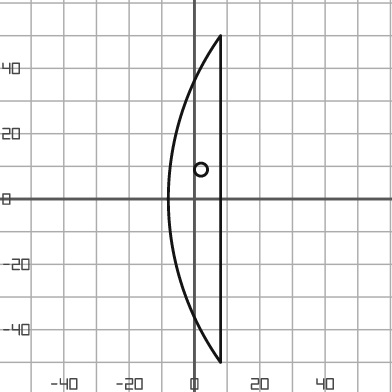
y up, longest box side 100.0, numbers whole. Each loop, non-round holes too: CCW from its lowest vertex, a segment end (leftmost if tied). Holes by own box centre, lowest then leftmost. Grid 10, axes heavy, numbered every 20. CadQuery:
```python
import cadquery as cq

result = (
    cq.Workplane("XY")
    .moveTo(8.0, -50.0)
    .lineTo(8.0, 50.0)
    .threePointArc((-8.0, 0.0), (8.0, -50.0))
    .close()
    .moveTo(2.0, 9.0)
    .circle(2.0)
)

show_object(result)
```